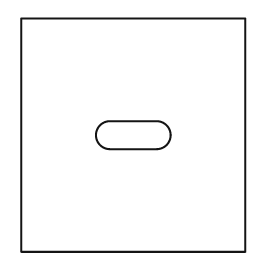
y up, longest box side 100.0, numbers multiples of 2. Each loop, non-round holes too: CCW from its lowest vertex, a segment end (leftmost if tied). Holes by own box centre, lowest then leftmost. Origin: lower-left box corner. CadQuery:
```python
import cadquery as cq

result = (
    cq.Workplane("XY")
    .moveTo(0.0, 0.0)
    .lineTo(96.0, 0.0)
    .lineTo(96.0, 100.0)
    .lineTo(0.0, 100.0)
    .close()
    .moveTo(38.0, 44.0)
    .lineTo(58.0, 44.0)
    .threePointArc((64.0, 50.0), (58.0, 56.0))
    .lineTo(38.0, 56.0)
    .threePointArc((32.0, 50.0), (38.0, 44.0))
    .close()
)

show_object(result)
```